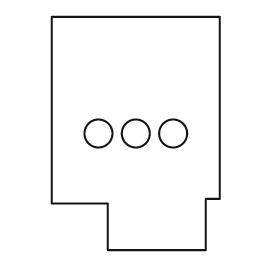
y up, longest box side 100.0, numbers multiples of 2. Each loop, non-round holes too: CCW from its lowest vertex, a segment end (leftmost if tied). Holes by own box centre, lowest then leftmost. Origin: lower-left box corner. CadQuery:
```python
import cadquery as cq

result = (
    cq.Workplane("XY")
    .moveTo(24.0, 0.0)
    .lineTo(66.0, 0.0)
    .lineTo(66.0, 22.0)
    .lineTo(72.0, 22.0)
    .lineTo(72.0, 100.0)
    .lineTo(0.0, 100.0)
    .lineTo(0.0, 20.0)
    .lineTo(24.0, 20.0)
    .close()
    .moveTo(20.0, 50.0)
    .circle(6.0)
    .moveTo(36.0, 50.0)
    .circle(6.0)
    .moveTo(52.0, 50.0)
    .circle(6.0)
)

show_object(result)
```